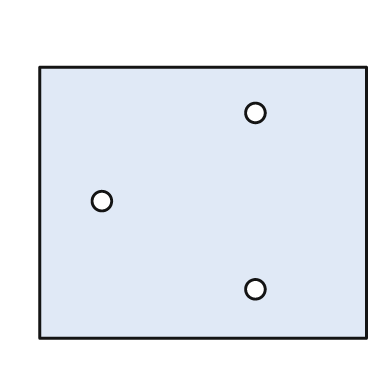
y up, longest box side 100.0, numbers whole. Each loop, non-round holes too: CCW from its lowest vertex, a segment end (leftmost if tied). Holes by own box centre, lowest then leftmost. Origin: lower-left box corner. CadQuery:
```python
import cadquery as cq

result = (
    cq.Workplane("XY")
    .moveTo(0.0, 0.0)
    .lineTo(100.0, 0.0)
    .lineTo(100.0, 83.0)
    .lineTo(0.0, 83.0)
    .close()
    .moveTo(66.0, 15.0)
    .circle(3.0)
    .moveTo(19.0, 42.0)
    .circle(3.0)
    .moveTo(66.0, 69.0)
    .circle(3.0)
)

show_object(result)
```